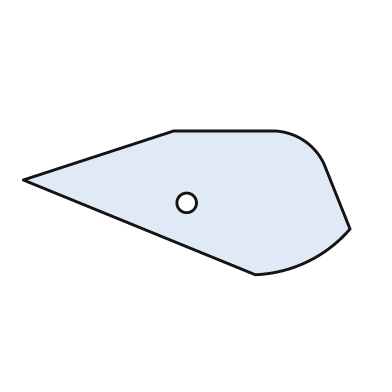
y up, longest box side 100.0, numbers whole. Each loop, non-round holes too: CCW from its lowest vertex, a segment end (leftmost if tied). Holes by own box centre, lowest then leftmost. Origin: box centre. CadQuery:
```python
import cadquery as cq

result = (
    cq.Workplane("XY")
    .moveTo(21.0, -22.0)
    .threePointArc((37.0, -18.0), (50.0, -8.0))
    .lineTo(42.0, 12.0)
    .threePointArc((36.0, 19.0), (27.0, 22.0))
    .lineTo(-4.0, 22.0)
    .lineTo(-50.0, 7.0)
    .close()
    .moveTo(0.0, 0.0)
    .circle(3.0)
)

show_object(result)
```